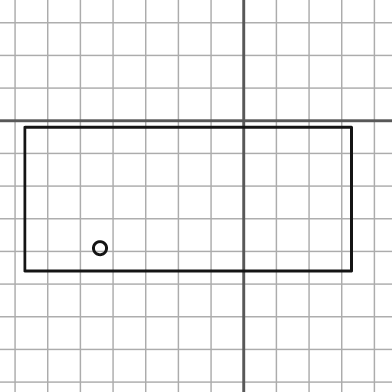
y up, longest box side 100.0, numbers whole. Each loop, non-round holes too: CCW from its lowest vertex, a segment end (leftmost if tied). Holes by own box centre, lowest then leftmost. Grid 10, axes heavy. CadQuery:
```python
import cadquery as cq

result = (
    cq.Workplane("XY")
    .moveTo(-67.0, -46.0)
    .lineTo(33.0, -46.0)
    .lineTo(33.0, -2.0)
    .lineTo(-67.0, -2.0)
    .close()
    .moveTo(-44.0, -39.0)
    .circle(2.0)
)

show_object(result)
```